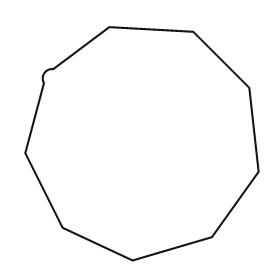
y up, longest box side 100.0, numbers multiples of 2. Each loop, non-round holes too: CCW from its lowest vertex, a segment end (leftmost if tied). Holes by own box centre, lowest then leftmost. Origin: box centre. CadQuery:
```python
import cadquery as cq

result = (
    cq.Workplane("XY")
    .moveTo(-4.0, -50.0)
    .lineTo(30.0, -40.0)
    .lineTo(50.0, -12.0)
    .lineTo(46.0, 24.0)
    .lineTo(22.0, 48.0)
    .lineTo(-14.0, 50.0)
    .lineTo(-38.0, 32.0)
    .threePointArc((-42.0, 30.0), (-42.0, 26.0))
    .lineTo(-50.0, -4.0)
    .lineTo(-34.0, -36.0)
    .close()
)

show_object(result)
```